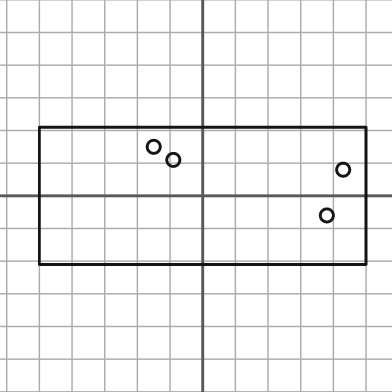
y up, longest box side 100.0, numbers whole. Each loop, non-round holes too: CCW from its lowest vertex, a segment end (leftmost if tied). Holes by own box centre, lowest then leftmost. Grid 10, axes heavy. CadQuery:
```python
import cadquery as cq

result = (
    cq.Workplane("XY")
    .moveTo(-50.0, -21.0)
    .lineTo(50.0, -21.0)
    .lineTo(50.0, 21.0)
    .lineTo(-50.0, 21.0)
    .close()
    .moveTo(38.0, -6.0)
    .circle(2.0)
    .moveTo(43.0, 8.0)
    .circle(2.0)
    .moveTo(-9.0, 11.0)
    .circle(2.0)
    .moveTo(-15.0, 15.0)
    .circle(2.0)
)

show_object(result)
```